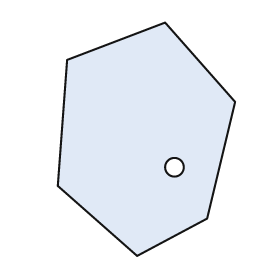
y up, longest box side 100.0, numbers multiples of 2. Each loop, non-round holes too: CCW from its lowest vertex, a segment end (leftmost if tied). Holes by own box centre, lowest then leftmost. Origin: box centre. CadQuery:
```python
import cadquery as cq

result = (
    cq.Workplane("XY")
    .moveTo(-4.0, -50.0)
    .lineTo(26.0, -34.0)
    .lineTo(38.0, 16.0)
    .lineTo(8.0, 50.0)
    .lineTo(-34.0, 34.0)
    .lineTo(-38.0, -20.0)
    .close()
    .moveTo(12.0, -12.0)
    .circle(4.0)
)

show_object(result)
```